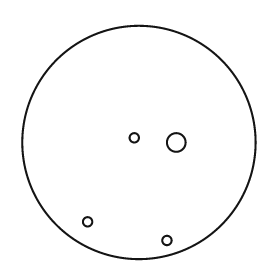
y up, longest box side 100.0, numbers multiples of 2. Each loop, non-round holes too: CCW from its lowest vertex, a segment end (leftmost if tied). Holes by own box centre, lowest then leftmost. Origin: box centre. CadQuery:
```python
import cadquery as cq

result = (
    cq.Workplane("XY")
    .moveTo(0.0, 0.0)
    .circle(50.0)
    .moveTo(12.0, -42.0)
    .circle(2.0)
    .moveTo(-22.0, -34.0)
    .circle(2.0)
    .moveTo(16.0, 0.0)
    .circle(4.0)
    .moveTo(-2.0, 2.0)
    .circle(2.0)
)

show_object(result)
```